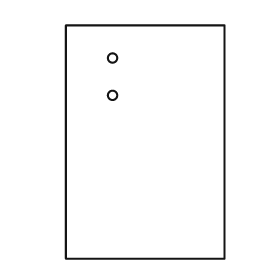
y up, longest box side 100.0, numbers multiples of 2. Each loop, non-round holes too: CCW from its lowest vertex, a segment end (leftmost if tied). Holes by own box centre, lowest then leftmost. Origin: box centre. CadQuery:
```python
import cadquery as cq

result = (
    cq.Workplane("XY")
    .moveTo(-34.0, -50.0)
    .lineTo(34.0, -50.0)
    .lineTo(34.0, 50.0)
    .lineTo(-34.0, 50.0)
    .close()
    .moveTo(-14.0, 20.0)
    .circle(2.0)
    .moveTo(-14.0, 36.0)
    .circle(2.0)
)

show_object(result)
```